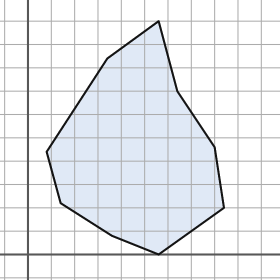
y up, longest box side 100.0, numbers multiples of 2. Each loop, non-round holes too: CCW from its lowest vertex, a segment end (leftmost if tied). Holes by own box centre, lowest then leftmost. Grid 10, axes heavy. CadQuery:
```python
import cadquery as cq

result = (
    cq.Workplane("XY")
    .moveTo(56.0, 0.0)
    .lineTo(84.0, 20.0)
    .lineTo(80.0, 46.0)
    .lineTo(64.0, 70.0)
    .lineTo(56.0, 100.0)
    .lineTo(34.0, 84.0)
    .lineTo(8.0, 44.0)
    .lineTo(14.0, 22.0)
    .lineTo(36.0, 8.0)
    .close()
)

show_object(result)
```